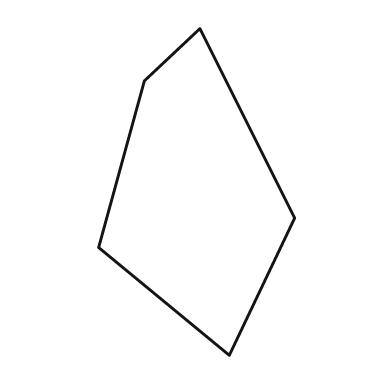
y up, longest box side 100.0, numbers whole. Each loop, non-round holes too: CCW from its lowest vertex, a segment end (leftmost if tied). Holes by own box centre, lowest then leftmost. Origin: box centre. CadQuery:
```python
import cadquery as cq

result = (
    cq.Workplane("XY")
    .moveTo(10.0, -50.0)
    .lineTo(30.0, -8.0)
    .lineTo(1.0, 50.0)
    .lineTo(-16.0, 34.0)
    .lineTo(-30.0, -17.0)
    .close()
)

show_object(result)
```